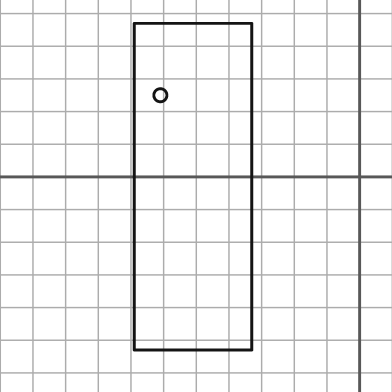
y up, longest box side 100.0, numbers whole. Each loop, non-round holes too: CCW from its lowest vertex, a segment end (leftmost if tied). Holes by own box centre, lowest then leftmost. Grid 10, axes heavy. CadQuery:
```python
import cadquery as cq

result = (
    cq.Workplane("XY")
    .moveTo(-69.0, -53.0)
    .lineTo(-33.0, -53.0)
    .lineTo(-33.0, 47.0)
    .lineTo(-69.0, 47.0)
    .close()
    .moveTo(-61.0, 25.0)
    .circle(2.0)
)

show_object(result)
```